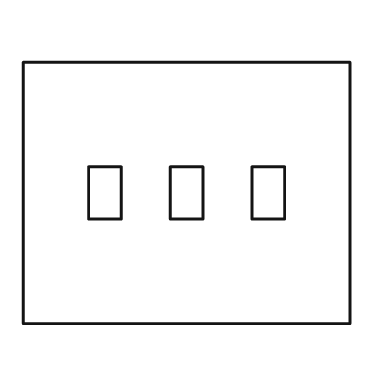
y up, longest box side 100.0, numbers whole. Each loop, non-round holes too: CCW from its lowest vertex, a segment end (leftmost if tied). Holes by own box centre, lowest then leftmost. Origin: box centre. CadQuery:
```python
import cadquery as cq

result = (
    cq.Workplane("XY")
    .moveTo(-50.0, -40.0)
    .lineTo(50.0, -40.0)
    .lineTo(50.0, 40.0)
    .lineTo(-50.0, 40.0)
    .close()
    .moveTo(-30.0, -8.0)
    .lineTo(-20.0, -8.0)
    .lineTo(-20.0, 8.0)
    .lineTo(-30.0, 8.0)
    .close()
    .moveTo(-5.0, -8.0)
    .lineTo(5.0, -8.0)
    .lineTo(5.0, 8.0)
    .lineTo(-5.0, 8.0)
    .close()
    .moveTo(20.0, -8.0)
    .lineTo(30.0, -8.0)
    .lineTo(30.0, 8.0)
    .lineTo(20.0, 8.0)
    .close()
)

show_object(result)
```